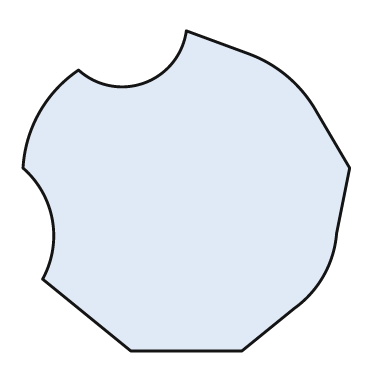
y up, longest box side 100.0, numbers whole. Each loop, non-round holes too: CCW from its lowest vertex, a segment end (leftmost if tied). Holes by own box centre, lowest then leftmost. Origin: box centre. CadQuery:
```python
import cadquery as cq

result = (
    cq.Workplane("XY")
    .moveTo(-17.0, -49.0)
    .lineTo(17.0, -49.0)
    .lineTo(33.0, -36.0)
    .threePointArc((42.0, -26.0), (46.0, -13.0))
    .lineTo(50.0, 7.0)
    .lineTo(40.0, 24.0)
    .threePointArc((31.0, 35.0), (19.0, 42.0))
    .lineTo(0.0, 49.0)
    .threePointArc((-13.0, 33.0), (-33.0, 37.0))
    .threePointArc((-45.0, 24.0), (-50.0, 7.0))
    .threePointArc((-41.0, -9.0), (-44.0, -27.0))
    .close()
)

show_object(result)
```